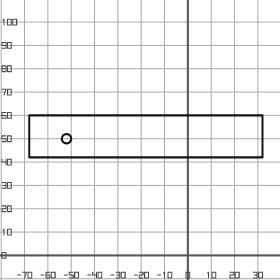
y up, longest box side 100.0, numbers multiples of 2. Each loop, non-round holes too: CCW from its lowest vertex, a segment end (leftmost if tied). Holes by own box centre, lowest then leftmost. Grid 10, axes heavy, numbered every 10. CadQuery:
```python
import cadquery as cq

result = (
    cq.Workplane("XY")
    .moveTo(-68.0, 42.0)
    .lineTo(32.0, 42.0)
    .lineTo(32.0, 60.0)
    .lineTo(-68.0, 60.0)
    .close()
    .moveTo(-52.0, 50.0)
    .circle(2.0)
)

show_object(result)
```